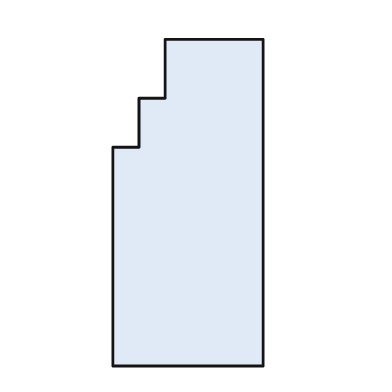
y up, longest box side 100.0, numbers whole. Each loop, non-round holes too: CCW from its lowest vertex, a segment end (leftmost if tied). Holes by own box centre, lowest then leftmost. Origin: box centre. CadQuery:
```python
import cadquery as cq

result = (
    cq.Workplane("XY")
    .moveTo(-23.0, -50.0)
    .lineTo(23.0, -50.0)
    .lineTo(23.0, 50.0)
    .lineTo(-7.0, 50.0)
    .lineTo(-7.0, 32.0)
    .lineTo(-15.0, 32.0)
    .lineTo(-15.0, 17.0)
    .lineTo(-23.0, 17.0)
    .close()
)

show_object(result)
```